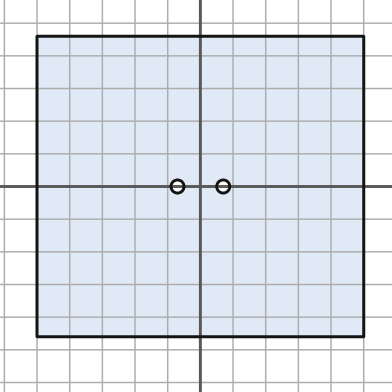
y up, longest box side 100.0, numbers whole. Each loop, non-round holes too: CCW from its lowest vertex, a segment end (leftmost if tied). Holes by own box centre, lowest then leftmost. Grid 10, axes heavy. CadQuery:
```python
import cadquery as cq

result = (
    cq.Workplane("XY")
    .moveTo(-50.0, -46.0)
    .lineTo(50.0, -46.0)
    .lineTo(50.0, 46.0)
    .lineTo(-50.0, 46.0)
    .close()
    .moveTo(-7.0, 0.0)
    .circle(2.0)
    .moveTo(7.0, 0.0)
    .circle(2.0)
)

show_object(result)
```